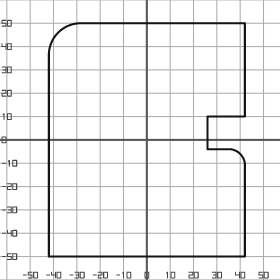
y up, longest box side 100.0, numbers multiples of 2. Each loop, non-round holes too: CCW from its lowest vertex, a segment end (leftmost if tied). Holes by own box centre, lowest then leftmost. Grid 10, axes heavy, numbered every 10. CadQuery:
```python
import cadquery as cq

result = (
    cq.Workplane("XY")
    .moveTo(-42.0, -50.0)
    .lineTo(42.0, -50.0)
    .lineTo(42.0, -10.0)
    .threePointArc((40.0, -6.0), (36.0, -4.0))
    .lineTo(26.0, -4.0)
    .lineTo(26.0, 10.0)
    .lineTo(42.0, 10.0)
    .lineTo(42.0, 50.0)
    .lineTo(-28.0, 50.0)
    .threePointArc((-38.0, 46.0), (-42.0, 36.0))
    .close()
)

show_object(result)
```